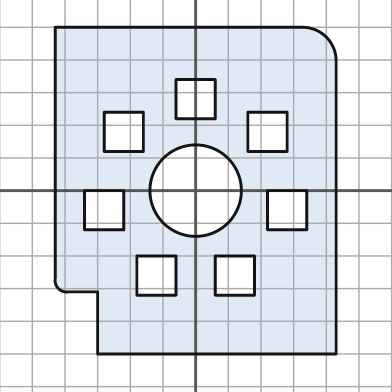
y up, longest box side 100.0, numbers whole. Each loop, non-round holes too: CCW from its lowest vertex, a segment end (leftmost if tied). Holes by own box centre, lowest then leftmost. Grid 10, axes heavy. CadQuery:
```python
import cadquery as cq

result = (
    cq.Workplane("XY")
    .moveTo(-30.0, -50.0)
    .lineTo(43.0, -50.0)
    .lineTo(43.0, 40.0)
    .threePointArc((40.0, 47.0), (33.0, 50.0))
    .lineTo(-43.0, 50.0)
    .lineTo(-43.0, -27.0)
    .threePointArc((-42.0, -30.0), (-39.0, -31.0))
    .lineTo(-30.0, -31.0)
    .close()
    .moveTo(-18.0, -32.0)
    .lineTo(-6.0, -32.0)
    .lineTo(-6.0, -20.0)
    .lineTo(-18.0, -20.0)
    .close()
    .moveTo(6.0, -32.0)
    .lineTo(18.0, -32.0)
    .lineTo(18.0, -20.0)
    .lineTo(6.0, -20.0)
    .close()
    .moveTo(-34.0, -12.0)
    .lineTo(-22.0, -12.0)
    .lineTo(-22.0, 0.0)
    .lineTo(-34.0, 0.0)
    .close()
    .moveTo(22.0, -12.0)
    .lineTo(34.0, -12.0)
    .lineTo(34.0, 0.0)
    .lineTo(22.0, 0.0)
    .close()
    .moveTo(0.0, 0.0)
    .circle(14.0)
    .moveTo(-28.0, 12.0)
    .lineTo(-16.0, 12.0)
    .lineTo(-16.0, 24.0)
    .lineTo(-28.0, 24.0)
    .close()
    .moveTo(16.0, 12.0)
    .lineTo(28.0, 12.0)
    .lineTo(28.0, 24.0)
    .lineTo(16.0, 24.0)
    .close()
    .moveTo(-6.0, 22.0)
    .lineTo(6.0, 22.0)
    .lineTo(6.0, 34.0)
    .lineTo(-6.0, 34.0)
    .close()
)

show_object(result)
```